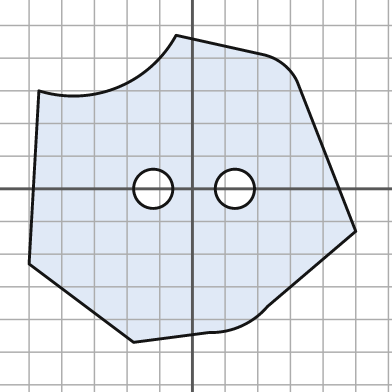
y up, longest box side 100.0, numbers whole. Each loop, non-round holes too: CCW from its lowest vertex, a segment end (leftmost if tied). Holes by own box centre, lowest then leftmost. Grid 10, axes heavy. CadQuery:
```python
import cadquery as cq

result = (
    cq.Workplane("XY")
    .moveTo(-18.0, -47.0)
    .lineTo(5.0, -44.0)
    .threePointArc((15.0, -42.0), (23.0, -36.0))
    .lineTo(50.0, -13.0)
    .lineTo(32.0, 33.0)
    .threePointArc((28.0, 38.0), (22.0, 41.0))
    .lineTo(-5.0, 47.0)
    .threePointArc((-23.0, 31.0), (-47.0, 30.0))
    .lineTo(-50.0, -23.0)
    .close()
    .moveTo(-12.0, 0.0)
    .circle(6.0)
    .moveTo(13.0, 0.0)
    .circle(6.0)
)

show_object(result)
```